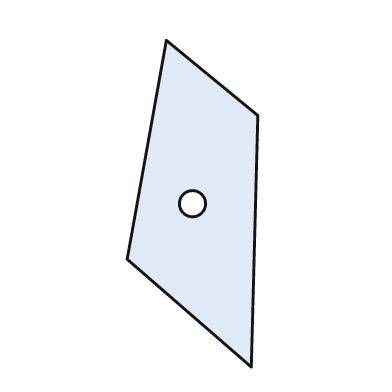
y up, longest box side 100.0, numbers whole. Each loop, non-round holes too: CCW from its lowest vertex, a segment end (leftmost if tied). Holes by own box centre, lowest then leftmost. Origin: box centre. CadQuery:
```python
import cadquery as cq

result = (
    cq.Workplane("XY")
    .moveTo(18.0, -50.0)
    .lineTo(20.0, 27.0)
    .lineTo(-8.0, 50.0)
    .lineTo(-20.0, -17.0)
    .close()
    .moveTo(0.0, 0.0)
    .circle(4.0)
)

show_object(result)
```